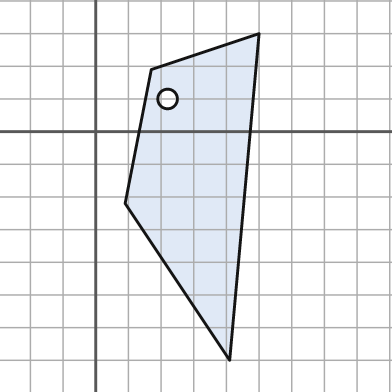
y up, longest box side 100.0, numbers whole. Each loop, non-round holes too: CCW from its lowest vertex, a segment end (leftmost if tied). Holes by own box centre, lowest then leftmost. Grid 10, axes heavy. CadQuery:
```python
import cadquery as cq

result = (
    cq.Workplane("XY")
    .moveTo(41.0, -70.0)
    .lineTo(50.0, 30.0)
    .lineTo(17.0, 19.0)
    .lineTo(9.0, -22.0)
    .close()
    .moveTo(22.0, 10.0)
    .circle(3.0)
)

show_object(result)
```